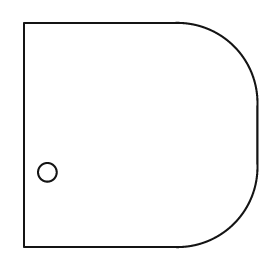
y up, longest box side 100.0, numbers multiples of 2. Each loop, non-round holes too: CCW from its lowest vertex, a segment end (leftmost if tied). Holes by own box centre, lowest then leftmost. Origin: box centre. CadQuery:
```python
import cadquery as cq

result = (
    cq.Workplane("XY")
    .moveTo(-50.0, -48.0)
    .lineTo(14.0, -48.0)
    .threePointArc((40.0, -38.0), (50.0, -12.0))
    .lineTo(50.0, 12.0)
    .threePointArc((40.0, 38.0), (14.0, 48.0))
    .lineTo(-50.0, 48.0)
    .close()
    .moveTo(-40.0, -16.0)
    .circle(4.0)
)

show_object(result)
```